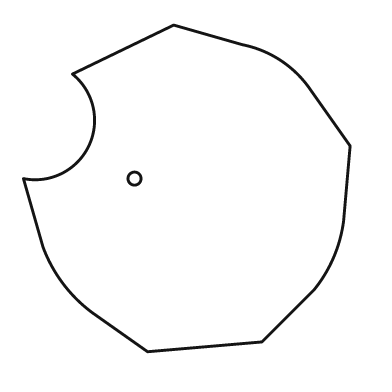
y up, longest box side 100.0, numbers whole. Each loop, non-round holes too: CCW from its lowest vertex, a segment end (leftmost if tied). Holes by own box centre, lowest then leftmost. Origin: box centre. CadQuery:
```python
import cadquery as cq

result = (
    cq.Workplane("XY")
    .moveTo(-12.0, -50.0)
    .lineTo(23.0, -47.0)
    .lineTo(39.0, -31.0)
    .threePointArc((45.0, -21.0), (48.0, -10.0))
    .lineTo(50.0, 13.0)
    .lineTo(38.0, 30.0)
    .threePointArc((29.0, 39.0), (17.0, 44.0))
    .lineTo(-4.0, 50.0)
    .lineTo(-35.0, 35.0)
    .threePointArc((-30.0, 13.0), (-50.0, 3.0))
    .lineTo(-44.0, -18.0)
    .threePointArc((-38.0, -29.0), (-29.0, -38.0))
    .close()
    .moveTo(-16.0, 3.0)
    .circle(2.0)
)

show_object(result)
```